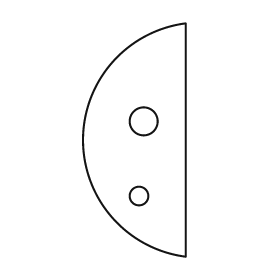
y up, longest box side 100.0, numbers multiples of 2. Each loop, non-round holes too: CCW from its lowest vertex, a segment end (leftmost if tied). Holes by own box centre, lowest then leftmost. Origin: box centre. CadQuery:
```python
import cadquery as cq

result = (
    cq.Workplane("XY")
    .moveTo(22.0, -50.0)
    .lineTo(22.0, 50.0)
    .threePointArc((-22.0, 0.0), (22.0, -50.0))
    .close()
    .moveTo(2.0, -24.0)
    .circle(4.0)
    .moveTo(4.0, 8.0)
    .circle(6.0)
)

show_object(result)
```